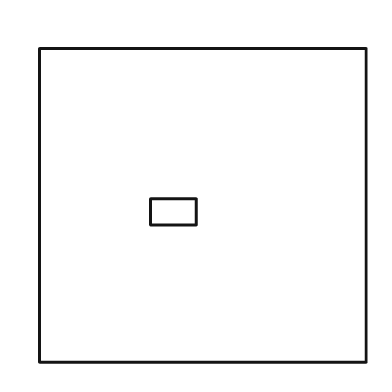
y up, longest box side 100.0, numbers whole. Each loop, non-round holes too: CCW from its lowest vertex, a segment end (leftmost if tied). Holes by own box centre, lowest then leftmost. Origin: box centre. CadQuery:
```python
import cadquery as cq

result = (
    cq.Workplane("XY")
    .moveTo(-50.0, -48.0)
    .lineTo(50.0, -48.0)
    .lineTo(50.0, 48.0)
    .lineTo(-50.0, 48.0)
    .close()
    .moveTo(-16.0, -6.0)
    .lineTo(-2.0, -6.0)
    .lineTo(-2.0, 2.0)
    .lineTo(-16.0, 2.0)
    .close()
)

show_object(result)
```